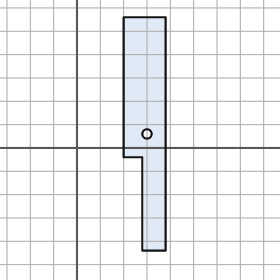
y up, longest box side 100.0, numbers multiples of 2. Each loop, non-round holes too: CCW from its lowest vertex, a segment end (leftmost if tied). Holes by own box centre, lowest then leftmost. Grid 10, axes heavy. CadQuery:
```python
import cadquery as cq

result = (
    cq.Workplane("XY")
    .moveTo(28.0, -44.0)
    .lineTo(38.0, -44.0)
    .lineTo(38.0, 56.0)
    .lineTo(20.0, 56.0)
    .lineTo(20.0, -4.0)
    .lineTo(28.0, -4.0)
    .close()
    .moveTo(30.0, 6.0)
    .circle(2.0)
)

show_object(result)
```